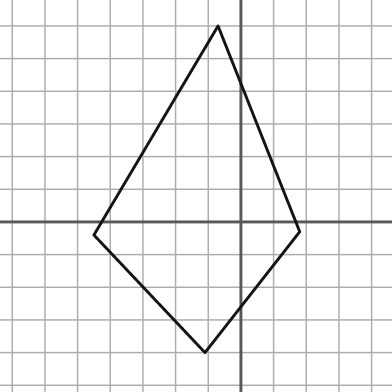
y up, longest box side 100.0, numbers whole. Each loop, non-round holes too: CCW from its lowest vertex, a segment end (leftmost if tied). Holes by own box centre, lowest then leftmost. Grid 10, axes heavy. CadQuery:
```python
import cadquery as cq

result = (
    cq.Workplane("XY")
    .moveTo(-11.0, -40.0)
    .lineTo(18.0, -3.0)
    .lineTo(-7.0, 60.0)
    .lineTo(-45.0, -4.0)
    .close()
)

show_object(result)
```